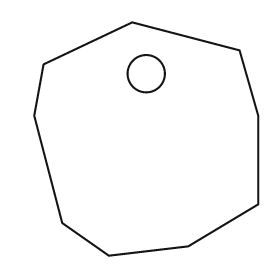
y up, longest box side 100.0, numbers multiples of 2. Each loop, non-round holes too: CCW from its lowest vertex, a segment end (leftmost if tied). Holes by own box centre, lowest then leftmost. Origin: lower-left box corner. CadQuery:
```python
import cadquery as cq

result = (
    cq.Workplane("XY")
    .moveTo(32.0, 0.0)
    .lineTo(66.0, 4.0)
    .lineTo(96.0, 22.0)
    .lineTo(96.0, 60.0)
    .lineTo(88.0, 88.0)
    .lineTo(42.0, 100.0)
    .lineTo(4.0, 82.0)
    .lineTo(0.0, 60.0)
    .lineTo(12.0, 14.0)
    .close()
    .moveTo(48.0, 78.0)
    .circle(8.0)
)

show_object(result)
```